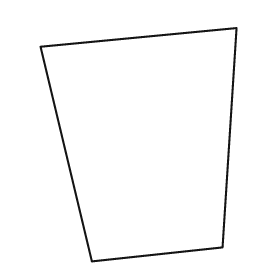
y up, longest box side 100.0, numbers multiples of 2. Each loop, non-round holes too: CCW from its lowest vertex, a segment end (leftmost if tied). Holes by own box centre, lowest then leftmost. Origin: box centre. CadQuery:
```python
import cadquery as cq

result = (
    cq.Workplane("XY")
    .moveTo(-20.0, -50.0)
    .lineTo(36.0, -44.0)
    .lineTo(42.0, 50.0)
    .lineTo(-42.0, 42.0)
    .close()
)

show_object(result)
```